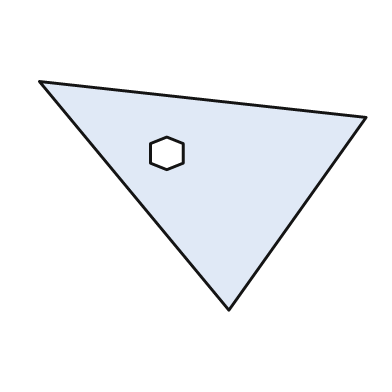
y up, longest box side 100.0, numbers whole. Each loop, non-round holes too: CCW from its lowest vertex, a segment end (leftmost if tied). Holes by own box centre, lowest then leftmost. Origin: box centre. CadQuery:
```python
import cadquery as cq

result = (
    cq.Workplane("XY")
    .moveTo(8.0, -35.0)
    .lineTo(50.0, 24.0)
    .lineTo(-50.0, 35.0)
    .close()
    .moveTo(-11.0, 8.0)
    .lineTo(-6.0, 10.0)
    .lineTo(-6.0, 16.0)
    .lineTo(-11.0, 18.0)
    .lineTo(-16.0, 16.0)
    .lineTo(-16.0, 10.0)
    .close()
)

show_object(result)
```